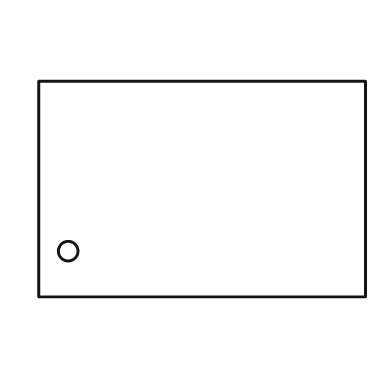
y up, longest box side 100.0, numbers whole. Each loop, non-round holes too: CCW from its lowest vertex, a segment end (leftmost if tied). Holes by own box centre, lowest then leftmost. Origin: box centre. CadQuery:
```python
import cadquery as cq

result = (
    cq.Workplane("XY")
    .moveTo(-50.0, -33.0)
    .lineTo(50.0, -33.0)
    .lineTo(50.0, 33.0)
    .lineTo(-50.0, 33.0)
    .close()
    .moveTo(-41.0, -19.0)
    .circle(3.0)
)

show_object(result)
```